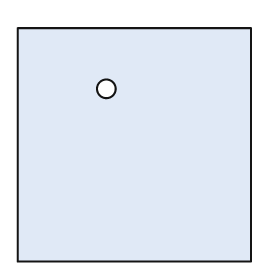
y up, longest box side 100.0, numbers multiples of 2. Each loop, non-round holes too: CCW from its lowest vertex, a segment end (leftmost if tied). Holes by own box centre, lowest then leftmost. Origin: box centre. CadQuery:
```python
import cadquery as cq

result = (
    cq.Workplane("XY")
    .moveTo(-50.0, -50.0)
    .lineTo(50.0, -50.0)
    .lineTo(50.0, 50.0)
    .lineTo(-50.0, 50.0)
    .close()
    .moveTo(-12.0, 24.0)
    .circle(4.0)
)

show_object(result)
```